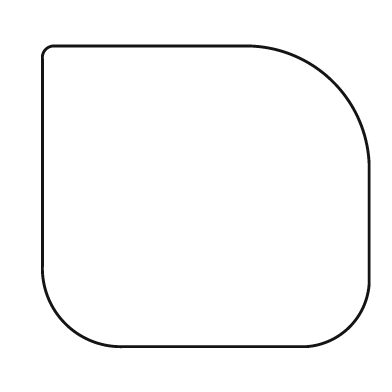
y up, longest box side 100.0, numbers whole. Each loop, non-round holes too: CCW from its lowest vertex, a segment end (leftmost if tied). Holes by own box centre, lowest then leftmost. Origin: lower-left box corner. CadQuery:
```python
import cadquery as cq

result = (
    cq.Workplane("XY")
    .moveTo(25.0, 0.0)
    .lineTo(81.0, 0.0)
    .threePointArc((94.0, 6.0), (100.0, 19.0))
    .lineTo(100.0, 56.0)
    .threePointArc((89.0, 81.0), (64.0, 92.0))
    .lineTo(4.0, 92.0)
    .threePointArc((1.0, 91.0), (0.0, 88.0))
    .lineTo(0.0, 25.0)
    .threePointArc((7.0, 7.0), (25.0, 0.0))
    .close()
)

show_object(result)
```